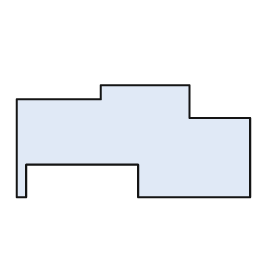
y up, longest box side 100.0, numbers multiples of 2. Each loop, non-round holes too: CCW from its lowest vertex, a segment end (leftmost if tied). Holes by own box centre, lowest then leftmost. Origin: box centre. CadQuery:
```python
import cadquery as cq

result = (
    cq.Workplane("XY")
    .moveTo(-50.0, -24.0)
    .lineTo(-46.0, -24.0)
    .lineTo(-46.0, -10.0)
    .lineTo(2.0, -10.0)
    .lineTo(2.0, -24.0)
    .lineTo(50.0, -24.0)
    .lineTo(50.0, 10.0)
    .lineTo(24.0, 10.0)
    .lineTo(24.0, 24.0)
    .lineTo(-14.0, 24.0)
    .lineTo(-14.0, 18.0)
    .lineTo(-50.0, 18.0)
    .close()
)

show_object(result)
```